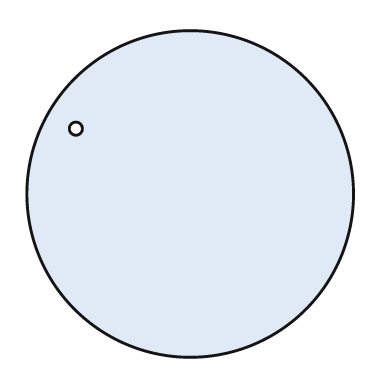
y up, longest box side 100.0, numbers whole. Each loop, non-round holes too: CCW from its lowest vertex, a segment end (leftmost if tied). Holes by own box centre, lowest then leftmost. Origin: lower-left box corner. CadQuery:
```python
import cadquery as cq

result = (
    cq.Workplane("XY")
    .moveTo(50.0, 50.0)
    .circle(50.0)
    .moveTo(15.0, 70.0)
    .circle(2.0)
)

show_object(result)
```